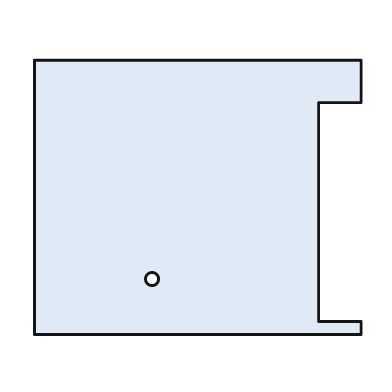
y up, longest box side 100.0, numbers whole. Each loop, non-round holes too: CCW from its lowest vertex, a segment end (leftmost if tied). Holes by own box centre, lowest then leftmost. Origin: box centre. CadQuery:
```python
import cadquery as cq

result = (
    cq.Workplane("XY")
    .moveTo(-50.0, -42.0)
    .lineTo(50.0, -42.0)
    .lineTo(50.0, -38.0)
    .lineTo(37.0, -38.0)
    .lineTo(37.0, 29.0)
    .lineTo(50.0, 29.0)
    .lineTo(50.0, 42.0)
    .lineTo(-50.0, 42.0)
    .close()
    .moveTo(-14.0, -25.0)
    .circle(2.0)
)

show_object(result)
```